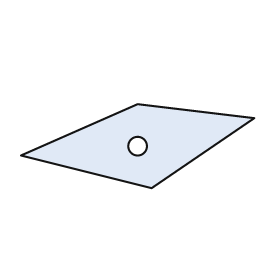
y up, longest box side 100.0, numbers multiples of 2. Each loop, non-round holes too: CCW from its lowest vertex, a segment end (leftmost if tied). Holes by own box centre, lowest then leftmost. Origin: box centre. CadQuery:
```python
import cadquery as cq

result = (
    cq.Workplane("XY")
    .moveTo(6.0, -18.0)
    .lineTo(50.0, 12.0)
    .lineTo(0.0, 18.0)
    .lineTo(-50.0, -4.0)
    .close()
    .moveTo(0.0, 0.0)
    .circle(4.0)
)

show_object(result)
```